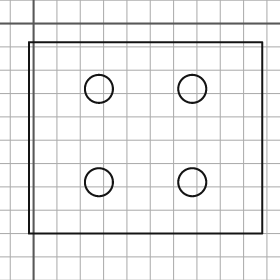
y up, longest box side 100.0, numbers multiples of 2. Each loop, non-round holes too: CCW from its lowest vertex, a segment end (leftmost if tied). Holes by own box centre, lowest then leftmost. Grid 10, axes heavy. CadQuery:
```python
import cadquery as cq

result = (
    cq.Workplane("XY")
    .moveTo(-2.0, -90.0)
    .lineTo(98.0, -90.0)
    .lineTo(98.0, -8.0)
    .lineTo(-2.0, -8.0)
    .close()
    .moveTo(28.0, -68.0)
    .circle(6.0)
    .moveTo(68.0, -68.0)
    .circle(6.0)
    .moveTo(28.0, -28.0)
    .circle(6.0)
    .moveTo(68.0, -28.0)
    .circle(6.0)
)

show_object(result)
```